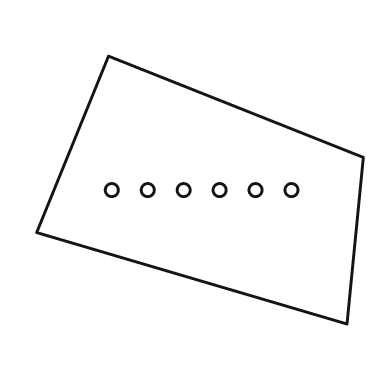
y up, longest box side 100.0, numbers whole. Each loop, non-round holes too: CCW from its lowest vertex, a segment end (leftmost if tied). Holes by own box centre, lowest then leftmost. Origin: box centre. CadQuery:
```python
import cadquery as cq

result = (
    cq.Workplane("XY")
    .moveTo(45.0, -41.0)
    .lineTo(50.0, 10.0)
    .lineTo(-28.0, 41.0)
    .lineTo(-50.0, -13.0)
    .close()
    .moveTo(-27.0, 0.0)
    .circle(2.0)
    .moveTo(-16.0, 0.0)
    .circle(2.0)
    .moveTo(-5.0, 0.0)
    .circle(2.0)
    .moveTo(6.0, 0.0)
    .circle(2.0)
    .moveTo(17.0, 0.0)
    .circle(2.0)
    .moveTo(28.0, 0.0)
    .circle(2.0)
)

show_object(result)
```